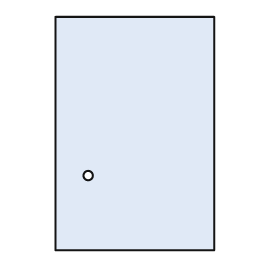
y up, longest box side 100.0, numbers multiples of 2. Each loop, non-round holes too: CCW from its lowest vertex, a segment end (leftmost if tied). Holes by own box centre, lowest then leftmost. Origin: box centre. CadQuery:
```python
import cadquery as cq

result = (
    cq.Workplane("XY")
    .moveTo(-34.0, -50.0)
    .lineTo(34.0, -50.0)
    .lineTo(34.0, 50.0)
    .lineTo(-34.0, 50.0)
    .close()
    .moveTo(-20.0, -18.0)
    .circle(2.0)
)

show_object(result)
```